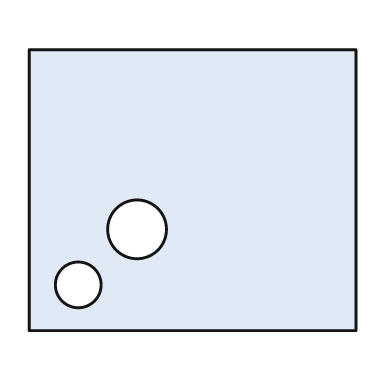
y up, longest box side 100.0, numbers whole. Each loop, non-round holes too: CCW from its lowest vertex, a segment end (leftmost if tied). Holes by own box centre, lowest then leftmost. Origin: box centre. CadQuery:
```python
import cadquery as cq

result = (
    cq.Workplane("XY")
    .moveTo(-50.0, -43.0)
    .lineTo(50.0, -43.0)
    .lineTo(50.0, 43.0)
    .lineTo(-50.0, 43.0)
    .close()
    .moveTo(-35.0, -29.0)
    .circle(7.0)
    .moveTo(-17.0, -12.0)
    .circle(9.0)
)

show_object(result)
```